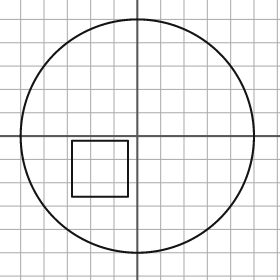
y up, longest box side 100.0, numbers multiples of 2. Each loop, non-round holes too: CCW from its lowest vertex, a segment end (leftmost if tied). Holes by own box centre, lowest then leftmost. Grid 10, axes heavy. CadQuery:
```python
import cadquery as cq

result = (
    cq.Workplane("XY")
    .moveTo(0.0, 0.0)
    .circle(50.0)
    .moveTo(-28.0, -26.0)
    .lineTo(-4.0, -26.0)
    .lineTo(-4.0, -2.0)
    .lineTo(-28.0, -2.0)
    .close()
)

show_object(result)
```